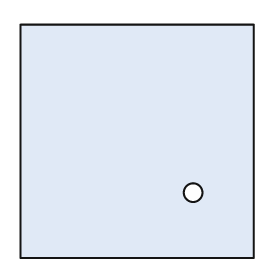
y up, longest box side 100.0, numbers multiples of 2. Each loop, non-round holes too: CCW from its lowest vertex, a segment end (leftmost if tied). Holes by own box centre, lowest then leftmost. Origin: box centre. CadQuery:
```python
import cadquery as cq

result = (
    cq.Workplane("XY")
    .moveTo(-50.0, -50.0)
    .lineTo(50.0, -50.0)
    .lineTo(50.0, 50.0)
    .lineTo(-50.0, 50.0)
    .close()
    .moveTo(24.0, -22.0)
    .circle(4.0)
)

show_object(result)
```